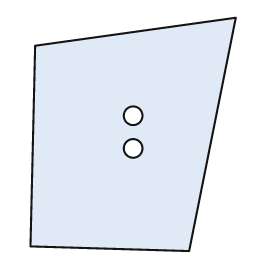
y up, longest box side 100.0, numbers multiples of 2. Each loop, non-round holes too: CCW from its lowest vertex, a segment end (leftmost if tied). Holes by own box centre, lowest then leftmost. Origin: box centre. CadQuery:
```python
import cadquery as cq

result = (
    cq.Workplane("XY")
    .moveTo(24.0, -50.0)
    .lineTo(44.0, 50.0)
    .lineTo(-42.0, 38.0)
    .lineTo(-44.0, -48.0)
    .close()
    .moveTo(0.0, -6.0)
    .circle(4.0)
    .moveTo(0.0, 8.0)
    .circle(4.0)
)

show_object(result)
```